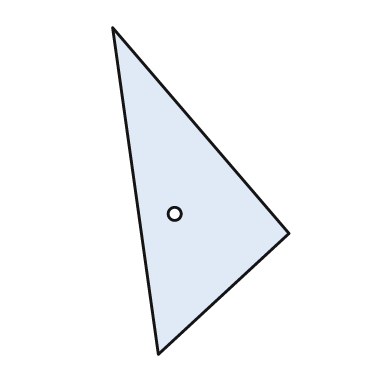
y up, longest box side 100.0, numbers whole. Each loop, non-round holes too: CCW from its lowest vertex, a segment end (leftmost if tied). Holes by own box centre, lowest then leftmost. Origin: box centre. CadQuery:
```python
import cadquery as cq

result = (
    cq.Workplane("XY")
    .moveTo(-13.0, -50.0)
    .lineTo(27.0, -13.0)
    .lineTo(-27.0, 50.0)
    .close()
    .moveTo(-8.0, -7.0)
    .circle(2.0)
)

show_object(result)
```